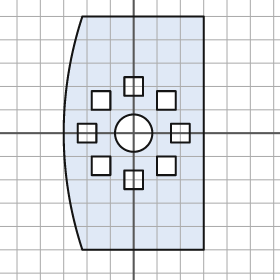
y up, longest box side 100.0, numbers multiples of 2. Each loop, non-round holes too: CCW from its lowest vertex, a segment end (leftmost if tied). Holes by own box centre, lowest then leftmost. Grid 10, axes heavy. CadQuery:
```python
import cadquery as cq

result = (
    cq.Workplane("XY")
    .moveTo(-22.0, -50.0)
    .lineTo(30.0, -50.0)
    .lineTo(30.0, 50.0)
    .lineTo(-22.0, 50.0)
    .threePointArc((-30.0, 0.0), (-22.0, -50.0))
    .close()
    .moveTo(-4.0, -24.0)
    .lineTo(4.0, -24.0)
    .lineTo(4.0, -16.0)
    .lineTo(-4.0, -16.0)
    .close()
    .moveTo(-18.0, -18.0)
    .lineTo(-10.0, -18.0)
    .lineTo(-10.0, -10.0)
    .lineTo(-18.0, -10.0)
    .close()
    .moveTo(10.0, -18.0)
    .lineTo(18.0, -18.0)
    .lineTo(18.0, -10.0)
    .lineTo(10.0, -10.0)
    .close()
    .moveTo(-24.0, -4.0)
    .lineTo(-16.0, -4.0)
    .lineTo(-16.0, 4.0)
    .lineTo(-24.0, 4.0)
    .close()
    .moveTo(0.0, 0.0)
    .circle(8.0)
    .moveTo(16.0, -4.0)
    .lineTo(24.0, -4.0)
    .lineTo(24.0, 4.0)
    .lineTo(16.0, 4.0)
    .close()
    .moveTo(-18.0, 10.0)
    .lineTo(-10.0, 10.0)
    .lineTo(-10.0, 18.0)
    .lineTo(-18.0, 18.0)
    .close()
    .moveTo(10.0, 10.0)
    .lineTo(18.0, 10.0)
    .lineTo(18.0, 18.0)
    .lineTo(10.0, 18.0)
    .close()
    .moveTo(-4.0, 16.0)
    .lineTo(4.0, 16.0)
    .lineTo(4.0, 24.0)
    .lineTo(-4.0, 24.0)
    .close()
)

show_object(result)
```